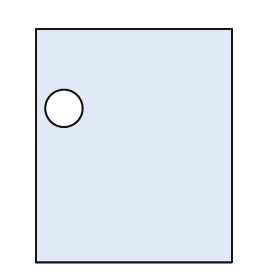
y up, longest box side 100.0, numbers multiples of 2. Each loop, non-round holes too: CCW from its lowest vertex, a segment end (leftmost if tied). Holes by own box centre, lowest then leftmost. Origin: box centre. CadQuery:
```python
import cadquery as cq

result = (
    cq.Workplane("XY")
    .moveTo(-42.0, -50.0)
    .lineTo(42.0, -50.0)
    .lineTo(42.0, 50.0)
    .lineTo(-42.0, 50.0)
    .close()
    .moveTo(-30.0, 16.0)
    .circle(8.0)
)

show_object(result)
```